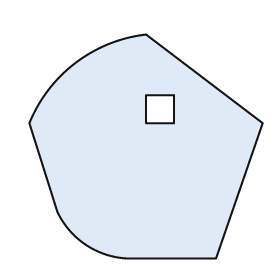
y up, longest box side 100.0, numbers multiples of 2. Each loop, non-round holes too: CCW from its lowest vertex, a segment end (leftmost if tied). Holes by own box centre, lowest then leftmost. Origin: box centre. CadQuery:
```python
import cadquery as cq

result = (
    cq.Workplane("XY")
    .moveTo(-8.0, -48.0)
    .lineTo(30.0, -48.0)
    .lineTo(50.0, 10.0)
    .lineTo(0.0, 48.0)
    .threePointArc((-30.0, 36.0), (-50.0, 10.0))
    .lineTo(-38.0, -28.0)
    .threePointArc((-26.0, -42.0), (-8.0, -48.0))
    .close()
    .moveTo(0.0, 10.0)
    .lineTo(12.0, 10.0)
    .lineTo(12.0, 22.0)
    .lineTo(0.0, 22.0)
    .close()
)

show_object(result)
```